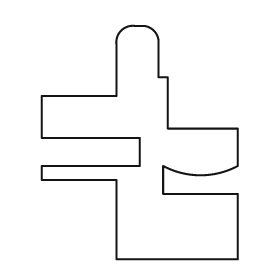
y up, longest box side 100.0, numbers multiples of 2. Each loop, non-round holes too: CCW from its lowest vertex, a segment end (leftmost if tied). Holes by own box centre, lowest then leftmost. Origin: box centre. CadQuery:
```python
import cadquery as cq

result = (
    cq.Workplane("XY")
    .moveTo(-10.0, -50.0)
    .lineTo(42.0, -50.0)
    .lineTo(42.0, -22.0)
    .lineTo(10.0, -22.0)
    .lineTo(10.0, -10.0)
    .threePointArc((26.0, -14.0), (42.0, -10.0))
    .lineTo(42.0, 6.0)
    .lineTo(12.0, 6.0)
    .lineTo(12.0, 28.0)
    .lineTo(8.0, 28.0)
    .lineTo(8.0, 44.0)
    .threePointArc((6.0, 48.0), (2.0, 50.0))
    .lineTo(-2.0, 50.0)
    .threePointArc((-8.0, 48.0), (-10.0, 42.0))
    .lineTo(-10.0, 20.0)
    .lineTo(-42.0, 20.0)
    .lineTo(-42.0, 2.0)
    .lineTo(0.0, 2.0)
    .lineTo(0.0, -10.0)
    .lineTo(-42.0, -10.0)
    .lineTo(-42.0, -16.0)
    .lineTo(-10.0, -16.0)
    .close()
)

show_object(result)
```